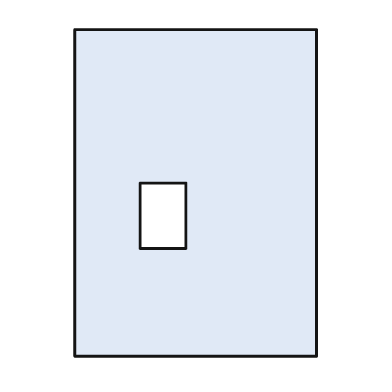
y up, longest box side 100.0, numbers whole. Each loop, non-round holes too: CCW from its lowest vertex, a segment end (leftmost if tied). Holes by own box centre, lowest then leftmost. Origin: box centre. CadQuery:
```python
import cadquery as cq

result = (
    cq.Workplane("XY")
    .moveTo(-37.0, -50.0)
    .lineTo(37.0, -50.0)
    .lineTo(37.0, 50.0)
    .lineTo(-37.0, 50.0)
    .close()
    .moveTo(-17.0, -17.0)
    .lineTo(-3.0, -17.0)
    .lineTo(-3.0, 3.0)
    .lineTo(-17.0, 3.0)
    .close()
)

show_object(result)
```